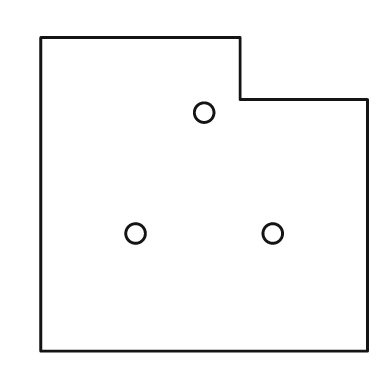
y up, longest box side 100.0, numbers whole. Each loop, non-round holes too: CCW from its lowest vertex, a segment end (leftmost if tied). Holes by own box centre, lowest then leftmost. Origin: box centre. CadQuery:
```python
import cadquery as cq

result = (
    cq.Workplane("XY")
    .moveTo(-50.0, -48.0)
    .lineTo(50.0, -48.0)
    .lineTo(50.0, 29.0)
    .lineTo(11.0, 29.0)
    .lineTo(11.0, 48.0)
    .lineTo(-50.0, 48.0)
    .close()
    .moveTo(-21.0, -12.0)
    .circle(3.0)
    .moveTo(21.0, -12.0)
    .circle(3.0)
    .moveTo(0.0, 25.0)
    .circle(3.0)
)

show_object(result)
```